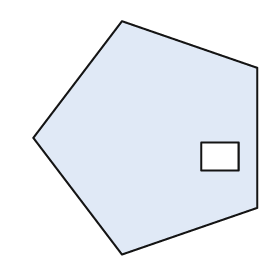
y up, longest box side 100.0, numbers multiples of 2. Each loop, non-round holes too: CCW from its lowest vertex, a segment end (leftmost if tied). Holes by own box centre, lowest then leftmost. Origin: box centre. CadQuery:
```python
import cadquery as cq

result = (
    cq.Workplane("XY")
    .moveTo(-10.0, -50.0)
    .lineTo(48.0, -30.0)
    .lineTo(48.0, 30.0)
    .lineTo(-10.0, 50.0)
    .lineTo(-48.0, 0.0)
    .close()
    .moveTo(24.0, -14.0)
    .lineTo(40.0, -14.0)
    .lineTo(40.0, -2.0)
    .lineTo(24.0, -2.0)
    .close()
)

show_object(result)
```